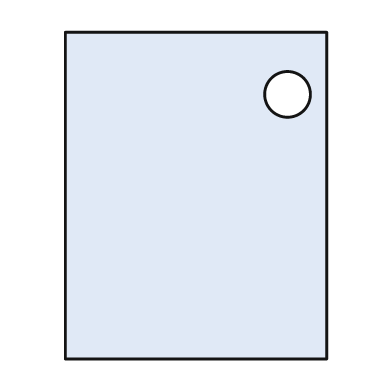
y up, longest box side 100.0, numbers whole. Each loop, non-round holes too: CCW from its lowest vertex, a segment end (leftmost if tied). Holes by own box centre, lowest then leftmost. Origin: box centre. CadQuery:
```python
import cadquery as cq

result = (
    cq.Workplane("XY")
    .moveTo(-40.0, -50.0)
    .lineTo(40.0, -50.0)
    .lineTo(40.0, 50.0)
    .lineTo(-40.0, 50.0)
    .close()
    .moveTo(28.0, 31.0)
    .circle(7.0)
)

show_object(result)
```